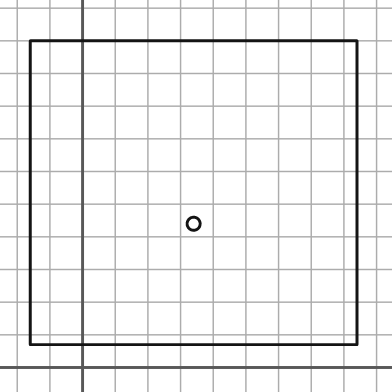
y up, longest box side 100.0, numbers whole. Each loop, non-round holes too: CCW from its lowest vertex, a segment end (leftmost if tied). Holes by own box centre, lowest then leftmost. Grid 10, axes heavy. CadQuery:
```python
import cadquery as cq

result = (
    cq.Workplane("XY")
    .moveTo(-16.0, 7.0)
    .lineTo(84.0, 7.0)
    .lineTo(84.0, 100.0)
    .lineTo(-16.0, 100.0)
    .close()
    .moveTo(34.0, 44.0)
    .circle(2.0)
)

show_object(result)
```